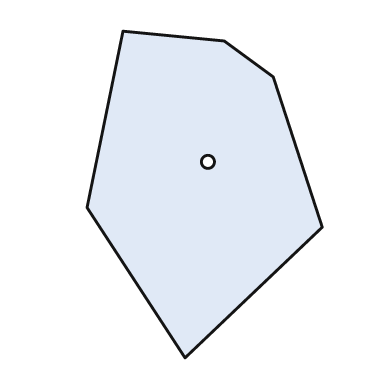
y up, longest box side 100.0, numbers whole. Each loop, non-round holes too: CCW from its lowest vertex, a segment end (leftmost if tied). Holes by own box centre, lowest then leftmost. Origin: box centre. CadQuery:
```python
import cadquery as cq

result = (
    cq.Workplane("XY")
    .moveTo(-6.0, -50.0)
    .lineTo(36.0, -10.0)
    .lineTo(21.0, 36.0)
    .lineTo(6.0, 47.0)
    .lineTo(-25.0, 50.0)
    .lineTo(-36.0, -4.0)
    .close()
    .moveTo(1.0, 10.0)
    .circle(2.0)
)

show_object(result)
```